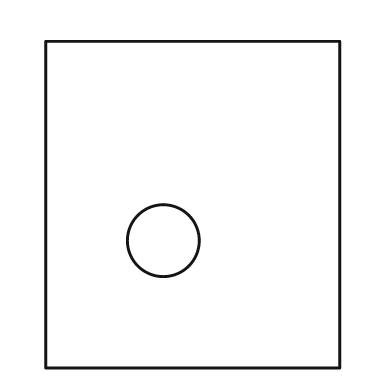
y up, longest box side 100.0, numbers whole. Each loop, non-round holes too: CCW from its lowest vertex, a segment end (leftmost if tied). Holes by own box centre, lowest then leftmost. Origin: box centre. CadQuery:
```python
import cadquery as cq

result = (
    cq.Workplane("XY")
    .moveTo(-45.0, -50.0)
    .lineTo(45.0, -50.0)
    .lineTo(45.0, 50.0)
    .lineTo(-45.0, 50.0)
    .close()
    .moveTo(-9.0, -11.0)
    .circle(11.0)
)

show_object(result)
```